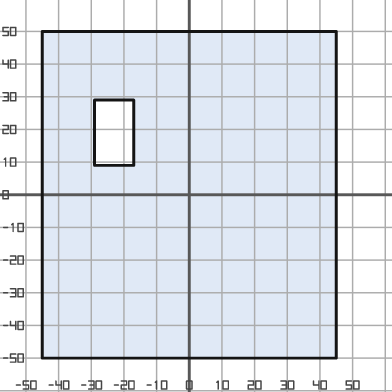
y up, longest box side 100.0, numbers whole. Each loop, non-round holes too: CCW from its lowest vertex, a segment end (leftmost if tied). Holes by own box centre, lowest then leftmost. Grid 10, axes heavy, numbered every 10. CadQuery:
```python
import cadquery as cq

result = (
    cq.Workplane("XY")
    .moveTo(-45.0, -50.0)
    .lineTo(45.0, -50.0)
    .lineTo(45.0, 50.0)
    .lineTo(-45.0, 50.0)
    .close()
    .moveTo(-29.0, 9.0)
    .lineTo(-17.0, 9.0)
    .lineTo(-17.0, 29.0)
    .lineTo(-29.0, 29.0)
    .close()
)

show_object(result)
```